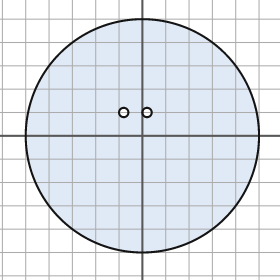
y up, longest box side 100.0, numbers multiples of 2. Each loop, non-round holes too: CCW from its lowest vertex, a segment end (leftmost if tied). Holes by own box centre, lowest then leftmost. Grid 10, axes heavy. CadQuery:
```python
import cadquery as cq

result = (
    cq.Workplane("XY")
    .moveTo(0.0, 0.0)
    .circle(50.0)
    .moveTo(-8.0, 10.0)
    .circle(2.0)
    .moveTo(2.0, 10.0)
    .circle(2.0)
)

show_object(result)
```